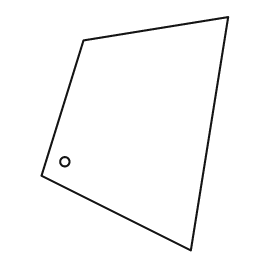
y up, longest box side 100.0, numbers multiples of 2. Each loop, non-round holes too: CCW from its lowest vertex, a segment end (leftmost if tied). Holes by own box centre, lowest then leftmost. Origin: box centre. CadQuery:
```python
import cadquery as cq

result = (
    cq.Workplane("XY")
    .moveTo(24.0, -50.0)
    .lineTo(40.0, 50.0)
    .lineTo(-22.0, 40.0)
    .lineTo(-40.0, -18.0)
    .close()
    .moveTo(-30.0, -12.0)
    .circle(2.0)
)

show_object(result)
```